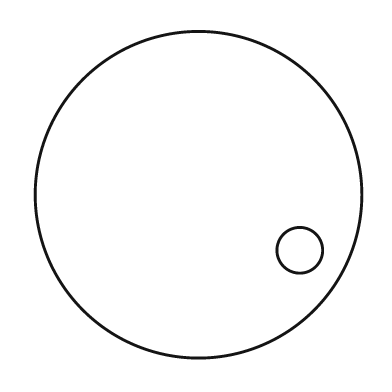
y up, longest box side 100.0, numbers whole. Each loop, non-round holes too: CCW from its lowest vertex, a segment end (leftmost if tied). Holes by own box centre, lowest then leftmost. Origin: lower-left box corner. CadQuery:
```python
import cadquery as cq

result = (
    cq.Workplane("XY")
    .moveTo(50.0, 50.0)
    .circle(50.0)
    .moveTo(81.0, 33.0)
    .circle(7.0)
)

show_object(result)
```